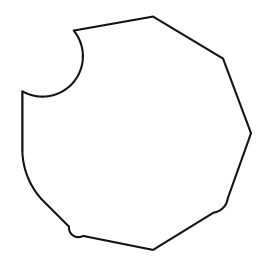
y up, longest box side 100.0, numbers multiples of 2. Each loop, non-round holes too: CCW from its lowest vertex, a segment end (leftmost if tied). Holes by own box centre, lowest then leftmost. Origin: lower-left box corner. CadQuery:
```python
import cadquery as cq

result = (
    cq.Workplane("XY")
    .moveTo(56.0, 0.0)
    .lineTo(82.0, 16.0)
    .threePointArc((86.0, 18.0), (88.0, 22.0))
    .lineTo(98.0, 50.0)
    .lineTo(86.0, 82.0)
    .lineTo(56.0, 100.0)
    .lineTo(22.0, 94.0)
    .threePointArc((22.0, 72.0), (0.0, 68.0))
    .lineTo(0.0, 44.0)
    .threePointArc((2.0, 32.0), (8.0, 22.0))
    .lineTo(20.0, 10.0)
    .threePointArc((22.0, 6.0), (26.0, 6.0))
    .close()
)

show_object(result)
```